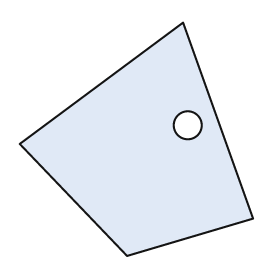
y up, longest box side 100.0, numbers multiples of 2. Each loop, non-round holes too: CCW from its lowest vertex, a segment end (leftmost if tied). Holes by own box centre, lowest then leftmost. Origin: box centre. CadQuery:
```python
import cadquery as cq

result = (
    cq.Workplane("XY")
    .moveTo(-4.0, -50.0)
    .lineTo(50.0, -34.0)
    .lineTo(20.0, 50.0)
    .lineTo(-50.0, -2.0)
    .close()
    .moveTo(22.0, 6.0)
    .circle(6.0)
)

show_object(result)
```